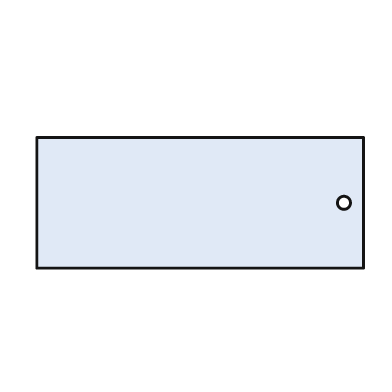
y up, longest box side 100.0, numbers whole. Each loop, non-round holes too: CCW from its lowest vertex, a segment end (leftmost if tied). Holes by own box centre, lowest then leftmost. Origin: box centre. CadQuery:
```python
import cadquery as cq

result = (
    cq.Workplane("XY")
    .moveTo(-50.0, -20.0)
    .lineTo(50.0, -20.0)
    .lineTo(50.0, 20.0)
    .lineTo(-50.0, 20.0)
    .close()
    .moveTo(44.0, 0.0)
    .circle(2.0)
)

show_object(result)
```